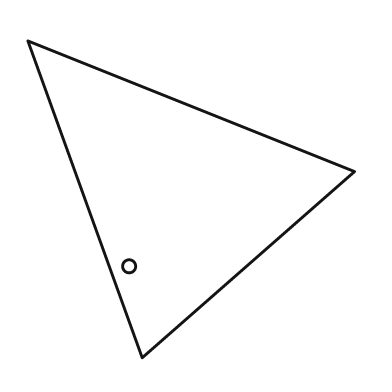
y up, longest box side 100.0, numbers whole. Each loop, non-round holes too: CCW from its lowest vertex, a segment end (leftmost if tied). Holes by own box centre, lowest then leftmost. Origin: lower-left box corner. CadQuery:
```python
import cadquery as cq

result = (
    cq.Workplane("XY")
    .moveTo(35.0, 0.0)
    .lineTo(100.0, 57.0)
    .lineTo(0.0, 97.0)
    .close()
    .moveTo(31.0, 28.0)
    .circle(2.0)
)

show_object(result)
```